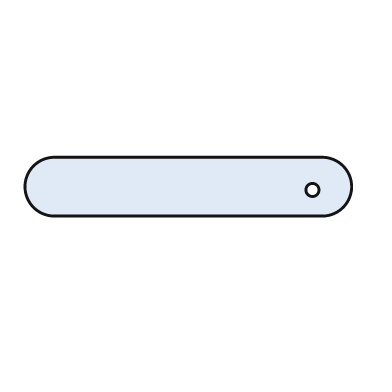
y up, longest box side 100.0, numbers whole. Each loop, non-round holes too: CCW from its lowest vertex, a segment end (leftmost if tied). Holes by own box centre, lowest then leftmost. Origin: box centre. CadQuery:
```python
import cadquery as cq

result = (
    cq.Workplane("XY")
    .moveTo(-41.0, -9.0)
    .lineTo(41.0, -9.0)
    .threePointArc((50.0, 0.0), (41.0, 9.0))
    .lineTo(-41.0, 9.0)
    .threePointArc((-50.0, 0.0), (-41.0, -9.0))
    .close()
    .moveTo(38.0, -1.0)
    .circle(2.0)
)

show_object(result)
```